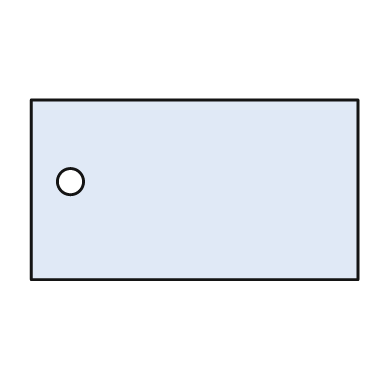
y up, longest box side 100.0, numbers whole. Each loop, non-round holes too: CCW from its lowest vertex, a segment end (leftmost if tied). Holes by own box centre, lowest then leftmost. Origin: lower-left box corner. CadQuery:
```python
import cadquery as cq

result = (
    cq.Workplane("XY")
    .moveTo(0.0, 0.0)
    .lineTo(100.0, 0.0)
    .lineTo(100.0, 55.0)
    .lineTo(0.0, 55.0)
    .close()
    .moveTo(12.0, 30.0)
    .circle(4.0)
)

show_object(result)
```